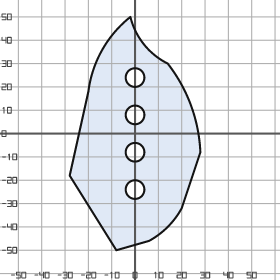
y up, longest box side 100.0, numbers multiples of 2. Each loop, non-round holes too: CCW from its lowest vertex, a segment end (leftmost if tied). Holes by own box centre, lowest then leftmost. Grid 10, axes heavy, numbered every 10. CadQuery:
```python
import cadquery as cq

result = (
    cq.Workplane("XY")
    .moveTo(-8.0, -50.0)
    .lineTo(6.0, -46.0)
    .threePointArc((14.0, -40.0), (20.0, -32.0))
    .lineTo(28.0, -8.0)
    .threePointArc((24.0, 12.0), (14.0, 30.0))
    .threePointArc((4.0, 38.0), (-2.0, 50.0))
    .threePointArc((-14.0, 36.0), (-20.0, 18.0))
    .lineTo(-28.0, -18.0)
    .close()
    .moveTo(0.0, -24.0)
    .circle(4.0)
    .moveTo(0.0, -8.0)
    .circle(4.0)
    .moveTo(0.0, 8.0)
    .circle(4.0)
    .moveTo(0.0, 24.0)
    .circle(4.0)
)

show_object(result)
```